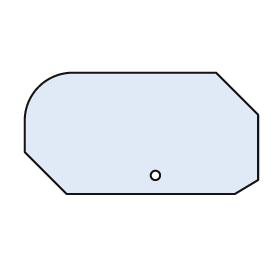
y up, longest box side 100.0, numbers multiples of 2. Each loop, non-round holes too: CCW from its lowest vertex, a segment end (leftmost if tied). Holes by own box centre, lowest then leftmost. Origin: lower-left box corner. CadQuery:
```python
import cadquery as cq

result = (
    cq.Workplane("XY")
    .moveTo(18.0, 0.0)
    .lineTo(90.0, 0.0)
    .lineTo(100.0, 6.0)
    .lineTo(100.0, 34.0)
    .lineTo(82.0, 52.0)
    .lineTo(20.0, 52.0)
    .threePointArc((6.0, 46.0), (0.0, 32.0))
    .lineTo(0.0, 18.0)
    .close()
    .moveTo(56.0, 8.0)
    .circle(2.0)
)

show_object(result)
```